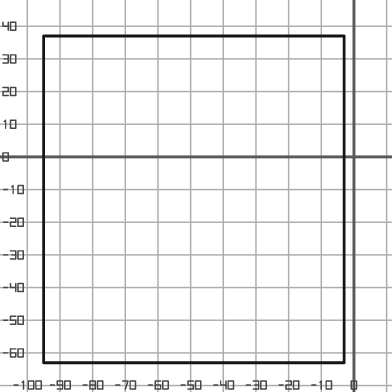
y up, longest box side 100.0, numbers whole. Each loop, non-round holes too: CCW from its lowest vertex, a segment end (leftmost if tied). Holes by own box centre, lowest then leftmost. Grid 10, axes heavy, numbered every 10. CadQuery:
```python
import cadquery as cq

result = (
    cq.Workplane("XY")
    .moveTo(-95.0, -63.0)
    .lineTo(-3.0, -63.0)
    .lineTo(-3.0, 37.0)
    .lineTo(-95.0, 37.0)
    .close()
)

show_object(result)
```